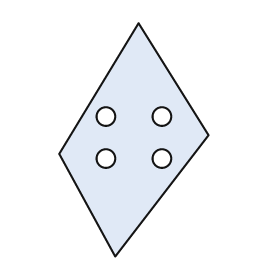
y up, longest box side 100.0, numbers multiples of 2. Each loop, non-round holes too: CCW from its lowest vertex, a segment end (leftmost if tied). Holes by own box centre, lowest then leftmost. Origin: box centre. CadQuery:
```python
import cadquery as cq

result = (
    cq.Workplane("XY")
    .moveTo(-8.0, -50.0)
    .lineTo(32.0, 2.0)
    .lineTo(2.0, 50.0)
    .lineTo(-32.0, -6.0)
    .close()
    .moveTo(-12.0, -8.0)
    .circle(4.0)
    .moveTo(12.0, -8.0)
    .circle(4.0)
    .moveTo(-12.0, 10.0)
    .circle(4.0)
    .moveTo(12.0, 10.0)
    .circle(4.0)
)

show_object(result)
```